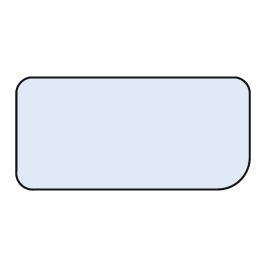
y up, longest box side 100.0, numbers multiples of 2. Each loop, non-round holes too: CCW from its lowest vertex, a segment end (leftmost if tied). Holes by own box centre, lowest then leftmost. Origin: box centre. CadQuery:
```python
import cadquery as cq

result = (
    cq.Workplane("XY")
    .moveTo(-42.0, -24.0)
    .lineTo(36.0, -24.0)
    .threePointArc((46.0, -20.0), (50.0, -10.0))
    .lineTo(50.0, 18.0)
    .threePointArc((48.0, 22.0), (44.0, 24.0))
    .lineTo(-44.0, 24.0)
    .threePointArc((-48.0, 22.0), (-50.0, 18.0))
    .lineTo(-50.0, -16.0)
    .threePointArc((-48.0, -22.0), (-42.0, -24.0))
    .close()
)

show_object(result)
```